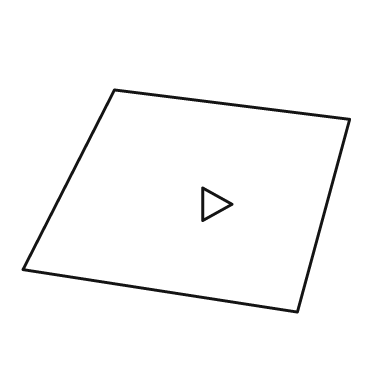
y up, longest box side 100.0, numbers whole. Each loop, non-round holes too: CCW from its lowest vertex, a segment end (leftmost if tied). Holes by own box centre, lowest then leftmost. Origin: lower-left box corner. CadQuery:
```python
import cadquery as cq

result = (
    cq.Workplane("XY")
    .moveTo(84.0, 0.0)
    .lineTo(100.0, 59.0)
    .lineTo(28.0, 68.0)
    .lineTo(0.0, 13.0)
    .close()
    .moveTo(55.0, 28.0)
    .lineTo(64.0, 33.0)
    .lineTo(55.0, 38.0)
    .close()
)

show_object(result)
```